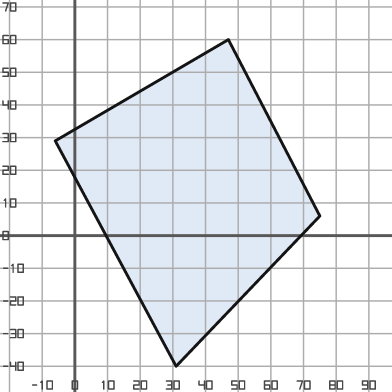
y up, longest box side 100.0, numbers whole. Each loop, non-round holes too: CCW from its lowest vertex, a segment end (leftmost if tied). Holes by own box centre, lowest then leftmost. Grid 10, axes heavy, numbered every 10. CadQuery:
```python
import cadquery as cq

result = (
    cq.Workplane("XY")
    .moveTo(31.0, -40.0)
    .lineTo(75.0, 6.0)
    .lineTo(47.0, 60.0)
    .lineTo(-6.0, 29.0)
    .close()
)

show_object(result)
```